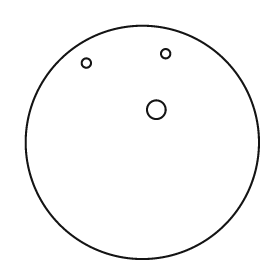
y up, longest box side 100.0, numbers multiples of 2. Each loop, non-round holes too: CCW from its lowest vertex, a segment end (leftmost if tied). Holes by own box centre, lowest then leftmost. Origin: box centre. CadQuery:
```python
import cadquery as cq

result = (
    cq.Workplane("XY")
    .moveTo(0.0, 0.0)
    .circle(50.0)
    .moveTo(6.0, 14.0)
    .circle(4.0)
    .moveTo(-24.0, 34.0)
    .circle(2.0)
    .moveTo(10.0, 38.0)
    .circle(2.0)
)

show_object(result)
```